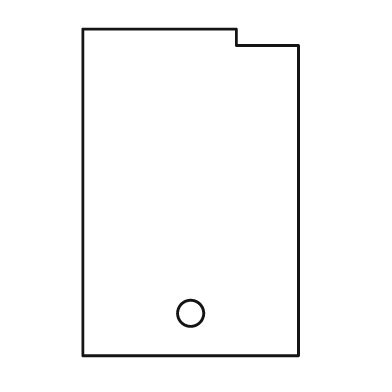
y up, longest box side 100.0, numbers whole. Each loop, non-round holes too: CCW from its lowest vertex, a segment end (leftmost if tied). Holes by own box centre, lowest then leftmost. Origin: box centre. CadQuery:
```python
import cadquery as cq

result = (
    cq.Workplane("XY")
    .moveTo(-33.0, -50.0)
    .lineTo(33.0, -50.0)
    .lineTo(33.0, 45.0)
    .lineTo(14.0, 45.0)
    .lineTo(14.0, 50.0)
    .lineTo(-33.0, 50.0)
    .close()
    .moveTo(0.0, -37.0)
    .circle(4.0)
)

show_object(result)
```